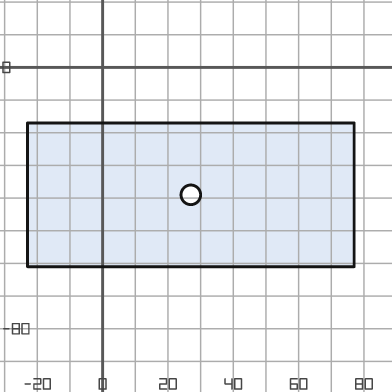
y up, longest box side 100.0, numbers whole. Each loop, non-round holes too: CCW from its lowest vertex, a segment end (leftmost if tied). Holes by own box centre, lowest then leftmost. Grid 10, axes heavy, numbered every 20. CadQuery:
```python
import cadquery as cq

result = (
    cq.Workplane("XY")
    .moveTo(-23.0, -61.0)
    .lineTo(77.0, -61.0)
    .lineTo(77.0, -17.0)
    .lineTo(-23.0, -17.0)
    .close()
    .moveTo(27.0, -39.0)
    .circle(3.0)
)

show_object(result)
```